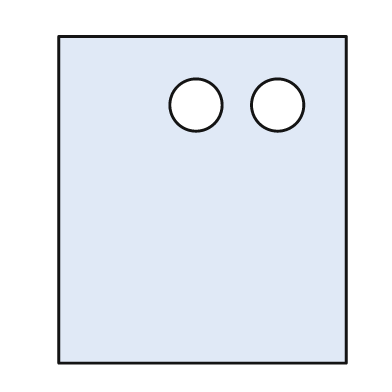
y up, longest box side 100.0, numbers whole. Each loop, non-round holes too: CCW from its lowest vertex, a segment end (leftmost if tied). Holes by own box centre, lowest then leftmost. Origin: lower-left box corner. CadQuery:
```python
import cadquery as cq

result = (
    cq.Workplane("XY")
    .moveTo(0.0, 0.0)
    .lineTo(88.0, 0.0)
    .lineTo(88.0, 100.0)
    .lineTo(0.0, 100.0)
    .close()
    .moveTo(42.0, 79.0)
    .circle(8.0)
    .moveTo(67.0, 79.0)
    .circle(8.0)
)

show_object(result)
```